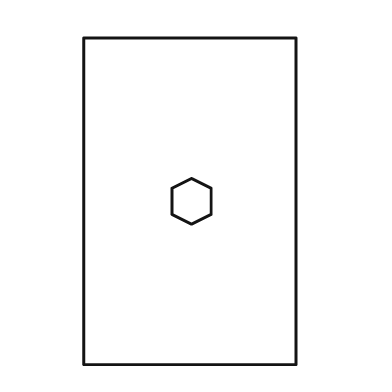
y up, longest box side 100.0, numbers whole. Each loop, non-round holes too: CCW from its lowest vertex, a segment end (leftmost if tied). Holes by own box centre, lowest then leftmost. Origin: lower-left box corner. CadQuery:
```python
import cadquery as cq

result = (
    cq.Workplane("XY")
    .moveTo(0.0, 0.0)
    .lineTo(65.0, 0.0)
    .lineTo(65.0, 100.0)
    .lineTo(0.0, 100.0)
    .close()
    .moveTo(33.0, 43.0)
    .lineTo(39.0, 46.0)
    .lineTo(39.0, 54.0)
    .lineTo(33.0, 57.0)
    .lineTo(27.0, 54.0)
    .lineTo(27.0, 46.0)
    .close()
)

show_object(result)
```